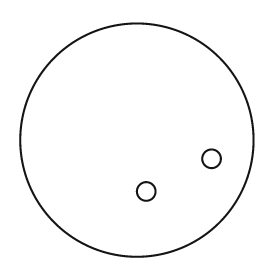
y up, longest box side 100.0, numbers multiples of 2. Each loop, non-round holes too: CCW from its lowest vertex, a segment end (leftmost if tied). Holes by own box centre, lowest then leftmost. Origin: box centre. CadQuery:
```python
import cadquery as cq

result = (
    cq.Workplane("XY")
    .moveTo(0.0, 0.0)
    .circle(50.0)
    .moveTo(4.0, -22.0)
    .circle(4.0)
    .moveTo(32.0, -8.0)
    .circle(4.0)
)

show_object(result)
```